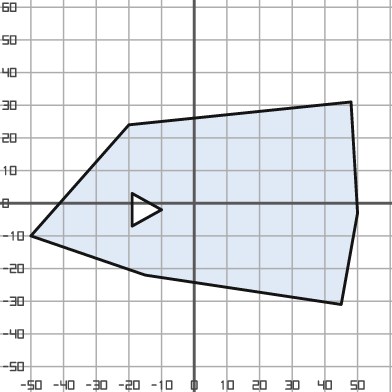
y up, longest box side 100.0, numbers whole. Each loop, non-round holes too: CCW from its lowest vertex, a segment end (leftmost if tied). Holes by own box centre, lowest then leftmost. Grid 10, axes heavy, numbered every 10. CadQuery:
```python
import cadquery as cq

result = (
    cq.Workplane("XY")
    .moveTo(45.0, -31.0)
    .lineTo(50.0, -3.0)
    .lineTo(48.0, 31.0)
    .lineTo(-20.0, 24.0)
    .lineTo(-50.0, -10.0)
    .lineTo(-15.0, -22.0)
    .close()
    .moveTo(-19.0, -7.0)
    .lineTo(-10.0, -2.0)
    .lineTo(-19.0, 3.0)
    .close()
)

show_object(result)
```